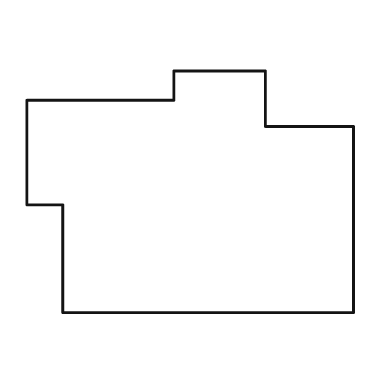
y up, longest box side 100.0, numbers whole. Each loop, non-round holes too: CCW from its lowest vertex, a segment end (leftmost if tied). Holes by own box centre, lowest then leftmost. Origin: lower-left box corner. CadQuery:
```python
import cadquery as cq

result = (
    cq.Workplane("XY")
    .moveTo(11.0, 0.0)
    .lineTo(100.0, 0.0)
    .lineTo(100.0, 57.0)
    .lineTo(73.0, 57.0)
    .lineTo(73.0, 74.0)
    .lineTo(45.0, 74.0)
    .lineTo(45.0, 65.0)
    .lineTo(0.0, 65.0)
    .lineTo(0.0, 33.0)
    .lineTo(11.0, 33.0)
    .close()
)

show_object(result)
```